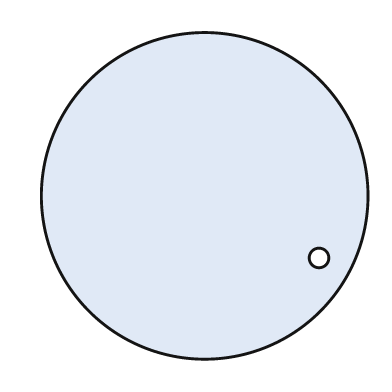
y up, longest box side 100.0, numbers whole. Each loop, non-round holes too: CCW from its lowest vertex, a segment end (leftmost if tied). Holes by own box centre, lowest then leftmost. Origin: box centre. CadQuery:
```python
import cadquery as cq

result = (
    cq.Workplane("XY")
    .moveTo(0.0, 0.0)
    .circle(50.0)
    .moveTo(35.0, -19.0)
    .circle(3.0)
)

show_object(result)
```